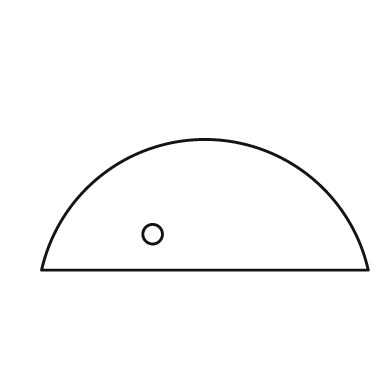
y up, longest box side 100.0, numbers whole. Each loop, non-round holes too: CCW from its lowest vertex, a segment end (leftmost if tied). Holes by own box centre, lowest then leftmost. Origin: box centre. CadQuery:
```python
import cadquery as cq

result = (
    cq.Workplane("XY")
    .moveTo(-50.0, -20.0)
    .lineTo(50.0, -20.0)
    .threePointArc((0.0, 20.0), (-50.0, -20.0))
    .close()
    .moveTo(-16.0, -9.0)
    .circle(3.0)
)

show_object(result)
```